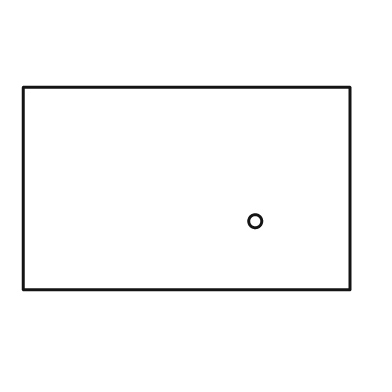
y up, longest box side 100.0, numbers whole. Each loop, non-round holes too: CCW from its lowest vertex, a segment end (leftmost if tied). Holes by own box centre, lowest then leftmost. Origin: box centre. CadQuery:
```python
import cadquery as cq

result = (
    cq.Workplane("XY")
    .moveTo(-50.0, -31.0)
    .lineTo(50.0, -31.0)
    .lineTo(50.0, 31.0)
    .lineTo(-50.0, 31.0)
    .close()
    .moveTo(21.0, -10.0)
    .circle(2.0)
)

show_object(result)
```